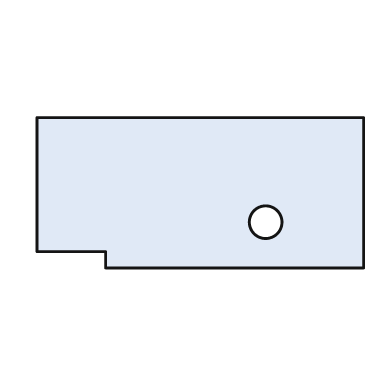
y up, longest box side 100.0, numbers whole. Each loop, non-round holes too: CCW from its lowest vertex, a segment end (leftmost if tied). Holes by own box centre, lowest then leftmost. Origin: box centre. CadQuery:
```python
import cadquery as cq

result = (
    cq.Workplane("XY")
    .moveTo(-29.0, -23.0)
    .lineTo(50.0, -23.0)
    .lineTo(50.0, 23.0)
    .lineTo(-50.0, 23.0)
    .lineTo(-50.0, -18.0)
    .lineTo(-29.0, -18.0)
    .close()
    .moveTo(20.0, -9.0)
    .circle(5.0)
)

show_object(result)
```